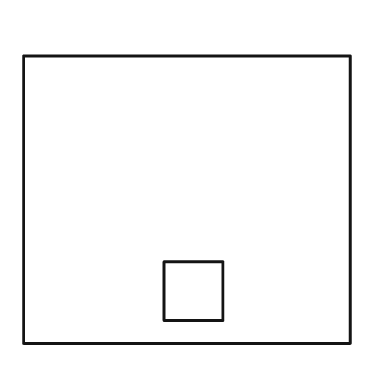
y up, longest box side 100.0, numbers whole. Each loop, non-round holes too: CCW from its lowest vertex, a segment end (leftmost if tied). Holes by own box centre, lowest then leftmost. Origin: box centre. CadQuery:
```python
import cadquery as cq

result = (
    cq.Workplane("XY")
    .moveTo(-50.0, -44.0)
    .lineTo(50.0, -44.0)
    .lineTo(50.0, 44.0)
    .lineTo(-50.0, 44.0)
    .close()
    .moveTo(-7.0, -37.0)
    .lineTo(11.0, -37.0)
    .lineTo(11.0, -19.0)
    .lineTo(-7.0, -19.0)
    .close()
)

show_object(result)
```